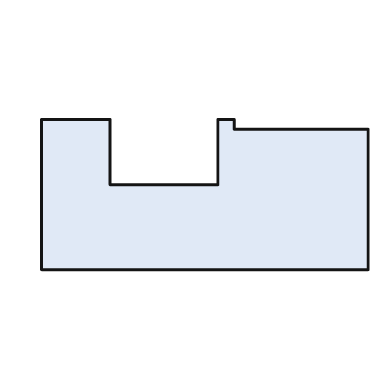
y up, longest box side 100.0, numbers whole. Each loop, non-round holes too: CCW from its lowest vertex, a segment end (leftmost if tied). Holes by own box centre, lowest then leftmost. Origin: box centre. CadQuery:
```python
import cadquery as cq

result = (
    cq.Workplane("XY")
    .moveTo(-50.0, -23.0)
    .lineTo(50.0, -23.0)
    .lineTo(50.0, 20.0)
    .lineTo(9.0, 20.0)
    .lineTo(9.0, 23.0)
    .lineTo(4.0, 23.0)
    .lineTo(4.0, 3.0)
    .lineTo(-29.0, 3.0)
    .lineTo(-29.0, 23.0)
    .lineTo(-50.0, 23.0)
    .close()
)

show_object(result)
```